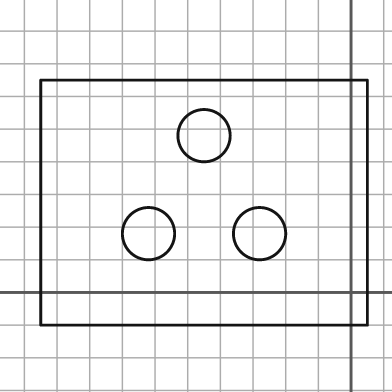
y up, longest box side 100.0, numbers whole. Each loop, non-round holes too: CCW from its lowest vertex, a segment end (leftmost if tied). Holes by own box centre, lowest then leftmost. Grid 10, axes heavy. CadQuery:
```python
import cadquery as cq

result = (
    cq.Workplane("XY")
    .moveTo(-95.0, -10.0)
    .lineTo(5.0, -10.0)
    .lineTo(5.0, 65.0)
    .lineTo(-95.0, 65.0)
    .close()
    .moveTo(-62.0, 18.0)
    .circle(8.0)
    .moveTo(-28.0, 18.0)
    .circle(8.0)
    .moveTo(-45.0, 48.0)
    .circle(8.0)
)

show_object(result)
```